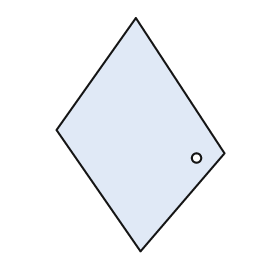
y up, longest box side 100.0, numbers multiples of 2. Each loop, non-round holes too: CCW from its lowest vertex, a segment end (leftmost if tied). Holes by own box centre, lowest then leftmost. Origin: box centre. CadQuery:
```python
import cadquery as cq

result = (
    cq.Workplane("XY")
    .moveTo(0.0, -50.0)
    .lineTo(36.0, -8.0)
    .lineTo(-2.0, 50.0)
    .lineTo(-36.0, 2.0)
    .close()
    .moveTo(24.0, -10.0)
    .circle(2.0)
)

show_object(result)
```